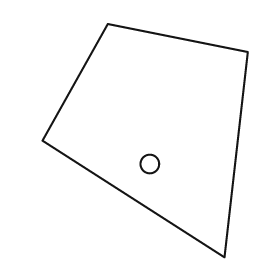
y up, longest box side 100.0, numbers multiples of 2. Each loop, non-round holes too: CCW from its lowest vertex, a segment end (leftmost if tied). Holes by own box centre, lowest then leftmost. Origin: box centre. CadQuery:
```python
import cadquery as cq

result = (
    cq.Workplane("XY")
    .moveTo(34.0, -50.0)
    .lineTo(44.0, 38.0)
    .lineTo(-16.0, 50.0)
    .lineTo(-44.0, 0.0)
    .close()
    .moveTo(2.0, -10.0)
    .circle(4.0)
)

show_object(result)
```